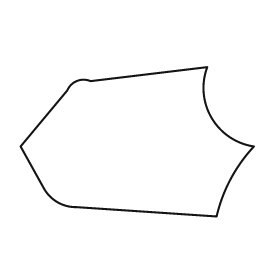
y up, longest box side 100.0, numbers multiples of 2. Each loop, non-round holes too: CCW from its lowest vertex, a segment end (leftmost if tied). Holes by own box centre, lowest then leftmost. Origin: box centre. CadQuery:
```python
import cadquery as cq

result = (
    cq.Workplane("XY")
    .moveTo(34.0, -32.0)
    .threePointArc((40.0, -16.0), (50.0, -2.0))
    .threePointArc((32.0, 10.0), (30.0, 32.0))
    .lineTo(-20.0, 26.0)
    .threePointArc((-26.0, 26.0), (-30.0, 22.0))
    .lineTo(-50.0, -2.0)
    .lineTo(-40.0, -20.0)
    .threePointArc((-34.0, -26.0), (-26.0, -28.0))
    .close()
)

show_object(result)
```